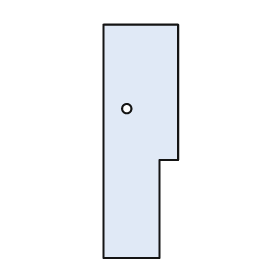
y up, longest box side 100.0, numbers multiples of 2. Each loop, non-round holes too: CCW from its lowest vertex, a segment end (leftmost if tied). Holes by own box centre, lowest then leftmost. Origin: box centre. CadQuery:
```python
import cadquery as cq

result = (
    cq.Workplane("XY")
    .moveTo(-16.0, -50.0)
    .lineTo(8.0, -50.0)
    .lineTo(8.0, -8.0)
    .lineTo(16.0, -8.0)
    .lineTo(16.0, 50.0)
    .lineTo(-16.0, 50.0)
    .close()
    .moveTo(-6.0, 14.0)
    .circle(2.0)
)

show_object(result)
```